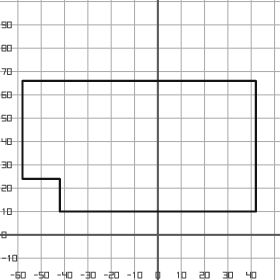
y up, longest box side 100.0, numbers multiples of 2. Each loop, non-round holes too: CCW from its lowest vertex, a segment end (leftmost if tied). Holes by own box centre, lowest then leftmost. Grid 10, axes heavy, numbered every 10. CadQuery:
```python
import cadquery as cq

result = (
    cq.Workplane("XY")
    .moveTo(-42.0, 10.0)
    .lineTo(42.0, 10.0)
    .lineTo(42.0, 66.0)
    .lineTo(-58.0, 66.0)
    .lineTo(-58.0, 24.0)
    .lineTo(-42.0, 24.0)
    .close()
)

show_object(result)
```